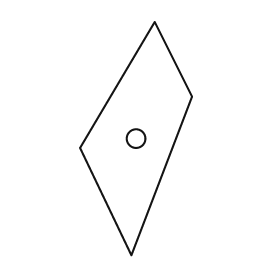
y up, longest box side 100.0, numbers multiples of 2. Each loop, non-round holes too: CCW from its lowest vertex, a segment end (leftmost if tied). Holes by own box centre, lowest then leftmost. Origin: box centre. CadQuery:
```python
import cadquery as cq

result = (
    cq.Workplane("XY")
    .moveTo(-2.0, -50.0)
    .lineTo(24.0, 18.0)
    .lineTo(8.0, 50.0)
    .lineTo(-24.0, -4.0)
    .close()
    .moveTo(0.0, 0.0)
    .circle(4.0)
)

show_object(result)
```